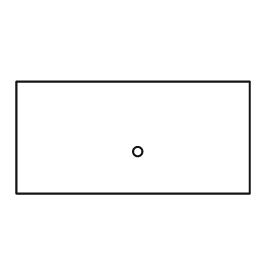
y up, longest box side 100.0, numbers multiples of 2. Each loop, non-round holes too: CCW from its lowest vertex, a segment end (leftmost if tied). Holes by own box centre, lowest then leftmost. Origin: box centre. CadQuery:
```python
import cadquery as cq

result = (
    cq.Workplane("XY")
    .moveTo(-50.0, -24.0)
    .lineTo(50.0, -24.0)
    .lineTo(50.0, 24.0)
    .lineTo(-50.0, 24.0)
    .close()
    .moveTo(2.0, -6.0)
    .circle(2.0)
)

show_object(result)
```